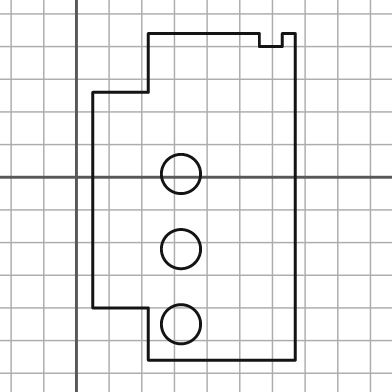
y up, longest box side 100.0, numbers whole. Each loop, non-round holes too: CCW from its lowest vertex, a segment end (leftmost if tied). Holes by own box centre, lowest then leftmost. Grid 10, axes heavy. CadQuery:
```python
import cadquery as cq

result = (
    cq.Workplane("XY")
    .moveTo(22.0, -56.0)
    .lineTo(67.0, -56.0)
    .lineTo(67.0, 44.0)
    .lineTo(63.0, 44.0)
    .lineTo(63.0, 40.0)
    .lineTo(56.0, 40.0)
    .lineTo(56.0, 44.0)
    .lineTo(22.0, 44.0)
    .lineTo(22.0, 26.0)
    .lineTo(5.0, 26.0)
    .lineTo(5.0, -40.0)
    .lineTo(22.0, -40.0)
    .close()
    .moveTo(32.0, -45.0)
    .circle(6.0)
    .moveTo(32.0, -22.0)
    .circle(6.0)
    .moveTo(32.0, 1.0)
    .circle(6.0)
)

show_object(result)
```